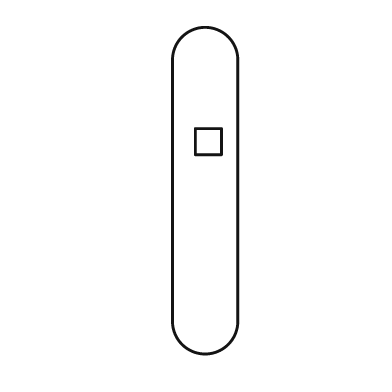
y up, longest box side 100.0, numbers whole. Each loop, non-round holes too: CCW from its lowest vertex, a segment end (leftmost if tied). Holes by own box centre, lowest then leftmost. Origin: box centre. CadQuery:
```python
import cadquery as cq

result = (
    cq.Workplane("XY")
    .moveTo(-10.0, -40.0)
    .threePointArc((0.0, -50.0), (10.0, -40.0))
    .lineTo(10.0, 40.0)
    .threePointArc((0.0, 50.0), (-10.0, 40.0))
    .close()
    .moveTo(-3.0, 11.0)
    .lineTo(5.0, 11.0)
    .lineTo(5.0, 19.0)
    .lineTo(-3.0, 19.0)
    .close()
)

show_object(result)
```